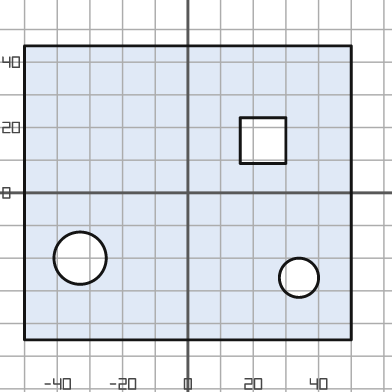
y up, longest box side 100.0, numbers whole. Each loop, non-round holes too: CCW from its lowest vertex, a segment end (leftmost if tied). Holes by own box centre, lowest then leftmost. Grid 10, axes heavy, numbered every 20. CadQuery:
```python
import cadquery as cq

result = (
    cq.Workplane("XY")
    .moveTo(-50.0, -45.0)
    .lineTo(50.0, -45.0)
    .lineTo(50.0, 45.0)
    .lineTo(-50.0, 45.0)
    .close()
    .moveTo(34.0, -26.0)
    .circle(6.0)
    .moveTo(-33.0, -20.0)
    .circle(8.0)
    .moveTo(16.0, 9.0)
    .lineTo(30.0, 9.0)
    .lineTo(30.0, 23.0)
    .lineTo(16.0, 23.0)
    .close()
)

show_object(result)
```